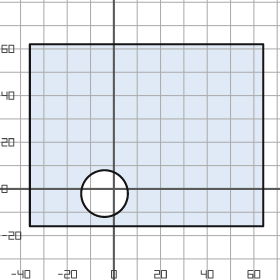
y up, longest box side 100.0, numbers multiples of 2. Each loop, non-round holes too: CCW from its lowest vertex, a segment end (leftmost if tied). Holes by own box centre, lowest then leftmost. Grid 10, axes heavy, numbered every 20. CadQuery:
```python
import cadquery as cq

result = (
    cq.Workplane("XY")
    .moveTo(-36.0, -16.0)
    .lineTo(64.0, -16.0)
    .lineTo(64.0, 62.0)
    .lineTo(-36.0, 62.0)
    .close()
    .moveTo(-4.0, -2.0)
    .circle(10.0)
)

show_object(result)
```